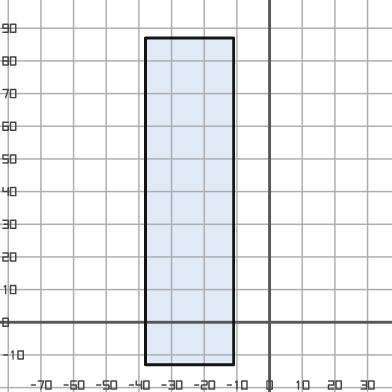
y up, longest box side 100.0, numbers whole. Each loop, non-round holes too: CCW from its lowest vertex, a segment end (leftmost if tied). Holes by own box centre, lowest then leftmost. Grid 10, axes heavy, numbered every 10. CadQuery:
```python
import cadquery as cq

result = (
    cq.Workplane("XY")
    .moveTo(-38.0, -13.0)
    .lineTo(-11.0, -13.0)
    .lineTo(-11.0, 87.0)
    .lineTo(-38.0, 87.0)
    .close()
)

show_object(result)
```